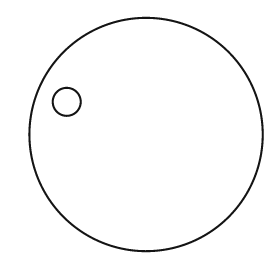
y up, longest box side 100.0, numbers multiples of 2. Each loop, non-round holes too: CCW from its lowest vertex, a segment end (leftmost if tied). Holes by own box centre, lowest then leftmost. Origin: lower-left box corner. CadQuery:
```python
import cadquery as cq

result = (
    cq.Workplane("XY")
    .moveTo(50.0, 50.0)
    .circle(50.0)
    .moveTo(16.0, 64.0)
    .circle(6.0)
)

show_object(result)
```